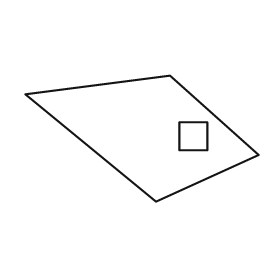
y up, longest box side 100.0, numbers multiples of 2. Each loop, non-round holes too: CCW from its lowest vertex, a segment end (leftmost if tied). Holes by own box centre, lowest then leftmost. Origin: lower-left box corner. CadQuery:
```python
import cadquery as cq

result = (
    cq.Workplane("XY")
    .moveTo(56.0, 0.0)
    .lineTo(100.0, 20.0)
    .lineTo(62.0, 54.0)
    .lineTo(0.0, 46.0)
    .close()
    .moveTo(66.0, 22.0)
    .lineTo(78.0, 22.0)
    .lineTo(78.0, 34.0)
    .lineTo(66.0, 34.0)
    .close()
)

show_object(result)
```